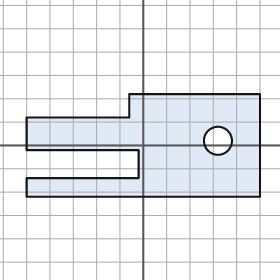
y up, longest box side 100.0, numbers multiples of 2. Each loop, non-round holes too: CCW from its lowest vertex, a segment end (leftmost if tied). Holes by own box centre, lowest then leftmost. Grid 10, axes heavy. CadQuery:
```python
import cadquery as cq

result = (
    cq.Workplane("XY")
    .moveTo(-50.0, -22.0)
    .lineTo(50.0, -22.0)
    .lineTo(50.0, 22.0)
    .lineTo(-6.0, 22.0)
    .lineTo(-6.0, 12.0)
    .lineTo(-50.0, 12.0)
    .lineTo(-50.0, -2.0)
    .lineTo(-2.0, -2.0)
    .lineTo(-2.0, -14.0)
    .lineTo(-50.0, -14.0)
    .close()
    .moveTo(32.0, 2.0)
    .circle(6.0)
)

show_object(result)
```